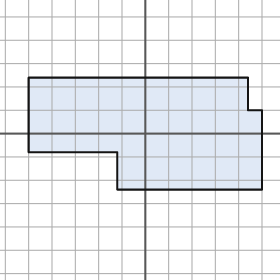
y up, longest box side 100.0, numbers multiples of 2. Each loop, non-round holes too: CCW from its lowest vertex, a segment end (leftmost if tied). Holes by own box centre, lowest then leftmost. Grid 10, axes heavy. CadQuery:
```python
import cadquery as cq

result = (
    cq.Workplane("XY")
    .moveTo(-12.0, -24.0)
    .lineTo(50.0, -24.0)
    .lineTo(50.0, 10.0)
    .lineTo(44.0, 10.0)
    .lineTo(44.0, 24.0)
    .lineTo(-50.0, 24.0)
    .lineTo(-50.0, -8.0)
    .lineTo(-12.0, -8.0)
    .close()
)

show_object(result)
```